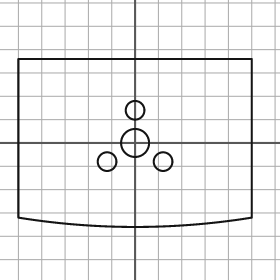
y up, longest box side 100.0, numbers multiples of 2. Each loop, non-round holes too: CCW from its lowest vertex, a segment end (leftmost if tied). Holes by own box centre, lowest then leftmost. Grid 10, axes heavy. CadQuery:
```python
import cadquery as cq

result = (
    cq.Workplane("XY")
    .moveTo(-50.0, -32.0)
    .threePointArc((0.0, -36.0), (50.0, -32.0))
    .lineTo(50.0, 36.0)
    .lineTo(-50.0, 36.0)
    .close()
    .moveTo(-12.0, -8.0)
    .circle(4.0)
    .moveTo(12.0, -8.0)
    .circle(4.0)
    .moveTo(0.0, 0.0)
    .circle(6.0)
    .moveTo(0.0, 14.0)
    .circle(4.0)
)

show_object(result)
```